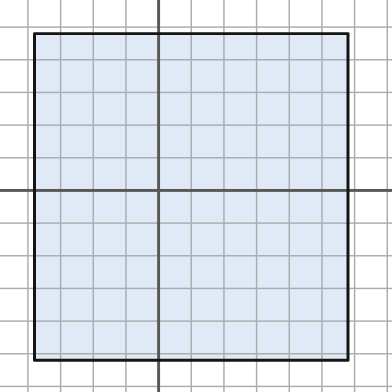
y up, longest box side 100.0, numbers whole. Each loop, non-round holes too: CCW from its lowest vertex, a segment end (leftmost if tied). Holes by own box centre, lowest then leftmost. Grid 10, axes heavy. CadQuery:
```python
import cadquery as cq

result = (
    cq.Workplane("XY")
    .moveTo(-38.0, -52.0)
    .lineTo(58.0, -52.0)
    .lineTo(58.0, 48.0)
    .lineTo(-38.0, 48.0)
    .close()
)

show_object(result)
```